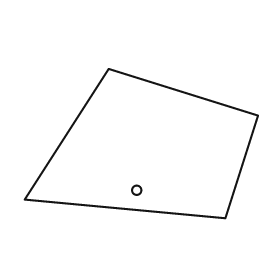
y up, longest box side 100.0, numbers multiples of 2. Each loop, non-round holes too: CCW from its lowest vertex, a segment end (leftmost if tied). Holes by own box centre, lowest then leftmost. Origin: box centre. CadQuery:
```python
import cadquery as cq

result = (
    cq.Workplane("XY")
    .moveTo(36.0, -32.0)
    .lineTo(50.0, 12.0)
    .lineTo(-14.0, 32.0)
    .lineTo(-50.0, -24.0)
    .close()
    .moveTo(-2.0, -20.0)
    .circle(2.0)
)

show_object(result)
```